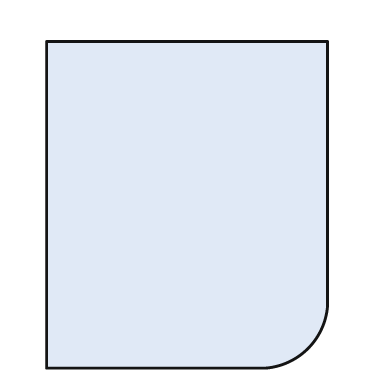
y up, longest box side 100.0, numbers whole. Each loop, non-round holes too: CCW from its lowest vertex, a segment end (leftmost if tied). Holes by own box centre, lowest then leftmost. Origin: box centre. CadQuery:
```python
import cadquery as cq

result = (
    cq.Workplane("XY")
    .moveTo(-43.0, -50.0)
    .lineTo(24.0, -50.0)
    .threePointArc((37.0, -44.0), (43.0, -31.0))
    .lineTo(43.0, 50.0)
    .lineTo(-43.0, 50.0)
    .close()
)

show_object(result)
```